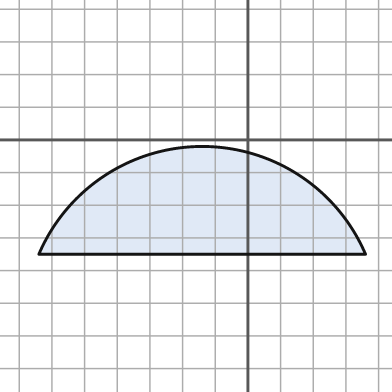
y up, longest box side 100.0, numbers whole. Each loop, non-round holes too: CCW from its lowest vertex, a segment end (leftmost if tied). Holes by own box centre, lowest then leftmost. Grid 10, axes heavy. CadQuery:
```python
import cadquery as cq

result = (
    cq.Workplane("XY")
    .moveTo(-64.0, -35.0)
    .lineTo(36.0, -35.0)
    .threePointArc((-14.0, -2.0), (-64.0, -35.0))
    .close()
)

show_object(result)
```